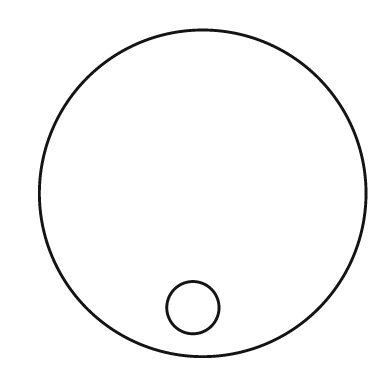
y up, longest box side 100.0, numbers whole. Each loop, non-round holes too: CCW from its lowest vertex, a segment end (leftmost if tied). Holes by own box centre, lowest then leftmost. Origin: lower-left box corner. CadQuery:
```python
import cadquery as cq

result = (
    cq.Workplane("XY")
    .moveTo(50.0, 50.0)
    .circle(50.0)
    .moveTo(47.0, 15.0)
    .circle(8.0)
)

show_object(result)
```